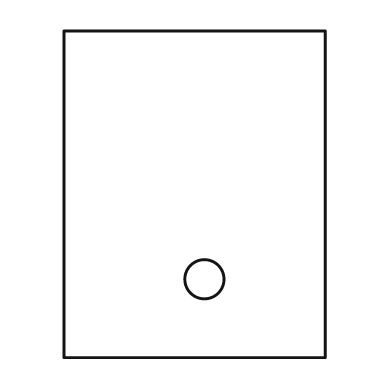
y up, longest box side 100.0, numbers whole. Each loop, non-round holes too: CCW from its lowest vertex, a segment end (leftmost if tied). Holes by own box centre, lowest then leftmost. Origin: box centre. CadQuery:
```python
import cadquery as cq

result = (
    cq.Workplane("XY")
    .moveTo(-40.0, -50.0)
    .lineTo(40.0, -50.0)
    .lineTo(40.0, 50.0)
    .lineTo(-40.0, 50.0)
    .close()
    .moveTo(3.0, -26.0)
    .circle(6.0)
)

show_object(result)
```